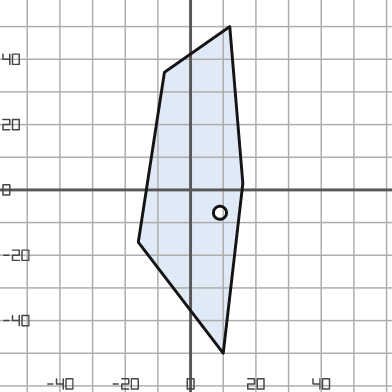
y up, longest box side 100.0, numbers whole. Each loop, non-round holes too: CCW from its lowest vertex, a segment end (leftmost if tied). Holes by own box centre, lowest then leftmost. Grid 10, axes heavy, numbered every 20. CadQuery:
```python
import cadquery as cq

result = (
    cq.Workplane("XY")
    .moveTo(10.0, -50.0)
    .lineTo(16.0, 2.0)
    .lineTo(12.0, 50.0)
    .lineTo(-8.0, 36.0)
    .lineTo(-16.0, -16.0)
    .close()
    .moveTo(9.0, -7.0)
    .circle(2.0)
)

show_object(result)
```